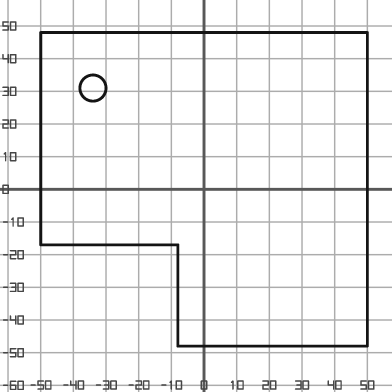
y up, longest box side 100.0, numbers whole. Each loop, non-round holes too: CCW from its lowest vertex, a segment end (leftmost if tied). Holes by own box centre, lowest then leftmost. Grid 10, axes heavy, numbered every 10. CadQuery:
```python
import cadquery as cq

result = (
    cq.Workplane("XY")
    .moveTo(-8.0, -48.0)
    .lineTo(50.0, -48.0)
    .lineTo(50.0, 48.0)
    .lineTo(-50.0, 48.0)
    .lineTo(-50.0, -17.0)
    .lineTo(-8.0, -17.0)
    .close()
    .moveTo(-34.0, 31.0)
    .circle(4.0)
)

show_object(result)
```